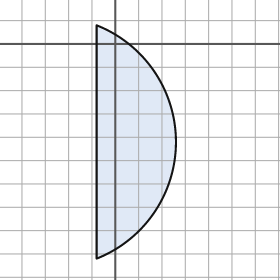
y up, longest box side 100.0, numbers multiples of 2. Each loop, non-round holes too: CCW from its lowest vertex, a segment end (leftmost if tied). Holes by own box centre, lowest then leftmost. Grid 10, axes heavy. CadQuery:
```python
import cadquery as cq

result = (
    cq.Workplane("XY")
    .moveTo(-8.0, -92.0)
    .threePointArc((26.0, -42.0), (-8.0, 8.0))
    .close()
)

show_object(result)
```